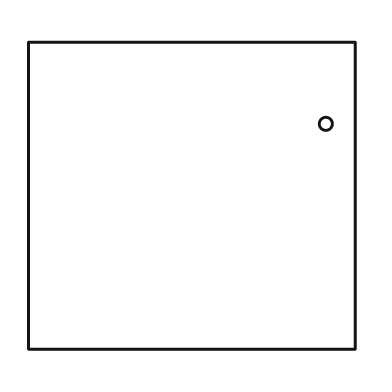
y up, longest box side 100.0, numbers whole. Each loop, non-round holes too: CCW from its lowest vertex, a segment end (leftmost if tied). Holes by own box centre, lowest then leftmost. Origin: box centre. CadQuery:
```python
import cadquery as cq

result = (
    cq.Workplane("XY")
    .moveTo(-50.0, -47.0)
    .lineTo(50.0, -47.0)
    .lineTo(50.0, 47.0)
    .lineTo(-50.0, 47.0)
    .close()
    .moveTo(41.0, 22.0)
    .circle(2.0)
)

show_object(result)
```